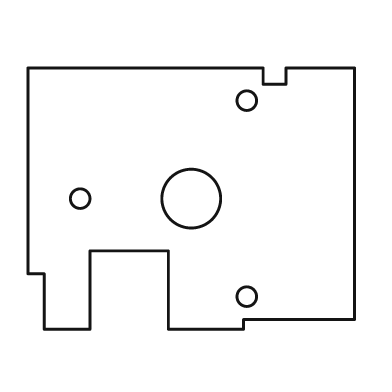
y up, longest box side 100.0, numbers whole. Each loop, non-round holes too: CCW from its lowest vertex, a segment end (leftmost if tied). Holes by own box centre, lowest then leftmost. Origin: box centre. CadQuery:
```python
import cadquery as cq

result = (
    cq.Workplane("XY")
    .moveTo(-45.0, -40.0)
    .lineTo(-31.0, -40.0)
    .lineTo(-31.0, -16.0)
    .lineTo(-7.0, -16.0)
    .lineTo(-7.0, -40.0)
    .lineTo(16.0, -40.0)
    .lineTo(16.0, -37.0)
    .lineTo(50.0, -37.0)
    .lineTo(50.0, 40.0)
    .lineTo(29.0, 40.0)
    .lineTo(29.0, 35.0)
    .lineTo(22.0, 35.0)
    .lineTo(22.0, 40.0)
    .lineTo(-50.0, 40.0)
    .lineTo(-50.0, -23.0)
    .lineTo(-45.0, -23.0)
    .close()
    .moveTo(17.0, -30.0)
    .circle(3.0)
    .moveTo(-34.0, 0.0)
    .circle(3.0)
    .moveTo(0.0, 0.0)
    .circle(9.0)
    .moveTo(17.0, 30.0)
    .circle(3.0)
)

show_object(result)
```